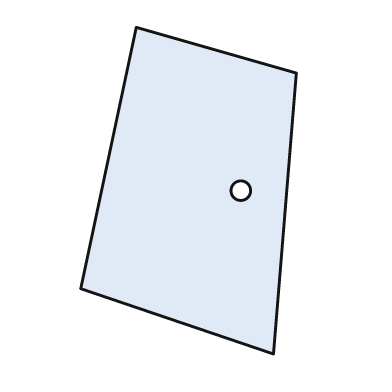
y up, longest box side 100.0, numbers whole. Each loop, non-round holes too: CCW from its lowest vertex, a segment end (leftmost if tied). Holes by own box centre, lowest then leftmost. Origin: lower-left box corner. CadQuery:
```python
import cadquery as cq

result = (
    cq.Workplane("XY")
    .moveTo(59.0, 0.0)
    .lineTo(66.0, 86.0)
    .lineTo(17.0, 100.0)
    .lineTo(0.0, 20.0)
    .close()
    .moveTo(49.0, 50.0)
    .circle(3.0)
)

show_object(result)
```